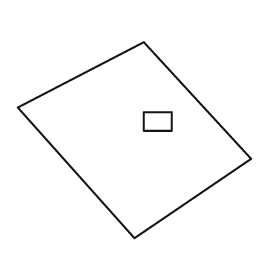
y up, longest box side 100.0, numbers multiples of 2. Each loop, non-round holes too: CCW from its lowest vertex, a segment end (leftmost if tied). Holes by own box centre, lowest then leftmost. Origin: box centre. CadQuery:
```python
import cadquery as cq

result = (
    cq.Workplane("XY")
    .moveTo(0.0, -42.0)
    .lineTo(50.0, -8.0)
    .lineTo(4.0, 42.0)
    .lineTo(-50.0, 14.0)
    .close()
    .moveTo(4.0, 4.0)
    .lineTo(16.0, 4.0)
    .lineTo(16.0, 12.0)
    .lineTo(4.0, 12.0)
    .close()
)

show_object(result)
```